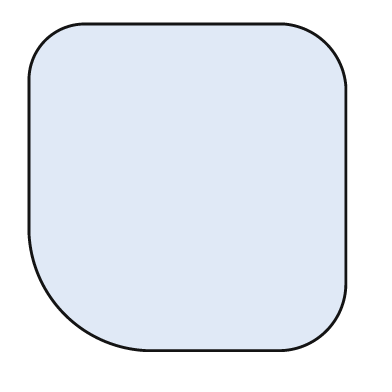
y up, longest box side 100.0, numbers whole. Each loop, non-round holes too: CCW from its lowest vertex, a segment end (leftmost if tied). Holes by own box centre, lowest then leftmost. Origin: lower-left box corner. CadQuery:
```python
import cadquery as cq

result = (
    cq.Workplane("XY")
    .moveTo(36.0, 0.0)
    .lineTo(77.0, 0.0)
    .threePointArc((91.0, 6.0), (97.0, 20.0))
    .lineTo(97.0, 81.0)
    .threePointArc((91.0, 94.0), (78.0, 100.0))
    .lineTo(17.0, 100.0)
    .threePointArc((5.0, 95.0), (0.0, 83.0))
    .lineTo(0.0, 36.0)
    .threePointArc((11.0, 11.0), (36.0, 0.0))
    .close()
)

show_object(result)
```